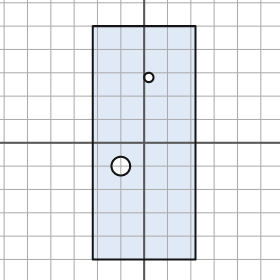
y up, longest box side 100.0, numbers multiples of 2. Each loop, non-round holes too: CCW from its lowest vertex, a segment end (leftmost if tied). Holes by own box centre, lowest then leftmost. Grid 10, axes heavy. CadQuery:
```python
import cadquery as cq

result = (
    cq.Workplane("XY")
    .moveTo(-22.0, -50.0)
    .lineTo(22.0, -50.0)
    .lineTo(22.0, 50.0)
    .lineTo(-22.0, 50.0)
    .close()
    .moveTo(-10.0, -10.0)
    .circle(4.0)
    .moveTo(2.0, 28.0)
    .circle(2.0)
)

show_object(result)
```